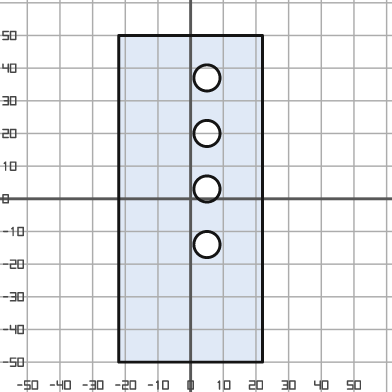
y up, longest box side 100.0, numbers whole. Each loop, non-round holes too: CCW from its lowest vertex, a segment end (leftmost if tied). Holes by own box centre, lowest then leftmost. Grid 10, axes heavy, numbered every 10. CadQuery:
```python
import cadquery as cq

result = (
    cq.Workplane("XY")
    .moveTo(-22.0, -50.0)
    .lineTo(22.0, -50.0)
    .lineTo(22.0, 50.0)
    .lineTo(-22.0, 50.0)
    .close()
    .moveTo(5.0, -14.0)
    .circle(4.0)
    .moveTo(5.0, 3.0)
    .circle(4.0)
    .moveTo(5.0, 20.0)
    .circle(4.0)
    .moveTo(5.0, 37.0)
    .circle(4.0)
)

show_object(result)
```